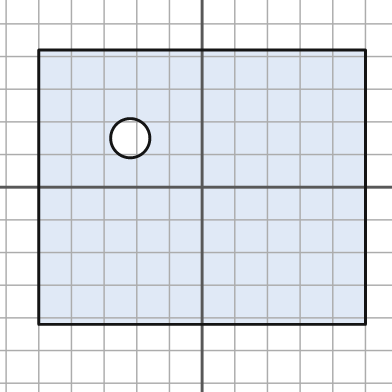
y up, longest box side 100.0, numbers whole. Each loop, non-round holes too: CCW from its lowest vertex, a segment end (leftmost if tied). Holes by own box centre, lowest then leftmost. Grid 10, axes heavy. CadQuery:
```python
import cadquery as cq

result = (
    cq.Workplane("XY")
    .moveTo(-50.0, -42.0)
    .lineTo(50.0, -42.0)
    .lineTo(50.0, 42.0)
    .lineTo(-50.0, 42.0)
    .close()
    .moveTo(-22.0, 15.0)
    .circle(6.0)
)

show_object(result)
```